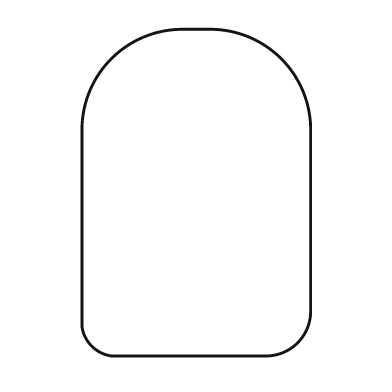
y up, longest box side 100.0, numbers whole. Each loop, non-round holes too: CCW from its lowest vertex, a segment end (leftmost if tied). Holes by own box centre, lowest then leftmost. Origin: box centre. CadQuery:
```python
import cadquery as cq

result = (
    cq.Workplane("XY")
    .moveTo(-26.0, -50.0)
    .lineTo(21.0, -50.0)
    .threePointArc((31.0, -46.0), (35.0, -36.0))
    .lineTo(35.0, 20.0)
    .threePointArc((26.0, 41.0), (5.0, 50.0))
    .lineTo(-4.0, 50.0)
    .threePointArc((-26.0, 41.0), (-35.0, 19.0))
    .lineTo(-35.0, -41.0)
    .threePointArc((-32.0, -47.0), (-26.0, -50.0))
    .close()
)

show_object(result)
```